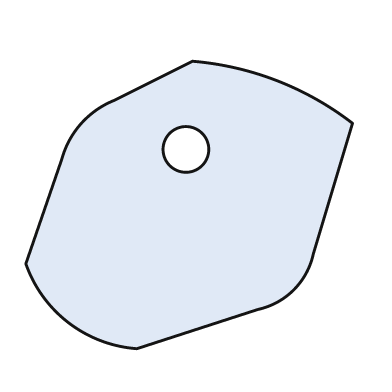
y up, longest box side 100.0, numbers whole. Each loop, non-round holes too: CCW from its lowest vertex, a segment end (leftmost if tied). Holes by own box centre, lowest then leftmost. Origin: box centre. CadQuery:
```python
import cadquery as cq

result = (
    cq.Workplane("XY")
    .moveTo(-16.0, -44.0)
    .lineTo(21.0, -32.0)
    .threePointArc((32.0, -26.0), (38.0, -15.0))
    .lineTo(50.0, 25.0)
    .threePointArc((27.0, 38.0), (1.0, 44.0))
    .lineTo(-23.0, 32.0)
    .threePointArc((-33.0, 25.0), (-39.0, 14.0))
    .lineTo(-50.0, -18.0)
    .threePointArc((-37.0, -36.0), (-16.0, -44.0))
    .close()
    .moveTo(-1.0, 17.0)
    .circle(7.0)
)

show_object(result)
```